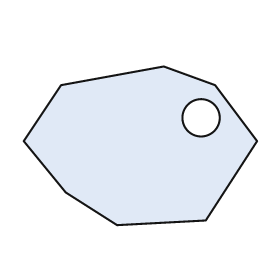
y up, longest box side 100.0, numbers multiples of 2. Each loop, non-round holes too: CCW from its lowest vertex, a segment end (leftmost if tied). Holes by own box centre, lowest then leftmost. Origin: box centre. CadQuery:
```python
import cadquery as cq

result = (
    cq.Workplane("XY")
    .moveTo(-10.0, -34.0)
    .lineTo(28.0, -32.0)
    .lineTo(50.0, 2.0)
    .lineTo(32.0, 26.0)
    .lineTo(10.0, 34.0)
    .lineTo(-34.0, 26.0)
    .lineTo(-50.0, 2.0)
    .lineTo(-32.0, -20.0)
    .close()
    .moveTo(26.0, 12.0)
    .circle(8.0)
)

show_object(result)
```